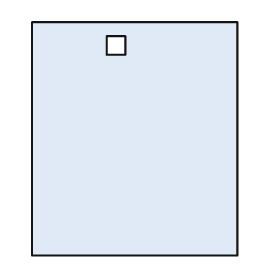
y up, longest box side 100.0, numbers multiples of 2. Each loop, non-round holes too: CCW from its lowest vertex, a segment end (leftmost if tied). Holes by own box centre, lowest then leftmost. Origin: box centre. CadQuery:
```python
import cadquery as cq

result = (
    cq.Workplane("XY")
    .moveTo(-44.0, -50.0)
    .lineTo(44.0, -50.0)
    .lineTo(44.0, 50.0)
    .lineTo(-44.0, 50.0)
    .close()
    .moveTo(-12.0, 36.0)
    .lineTo(-4.0, 36.0)
    .lineTo(-4.0, 44.0)
    .lineTo(-12.0, 44.0)
    .close()
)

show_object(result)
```